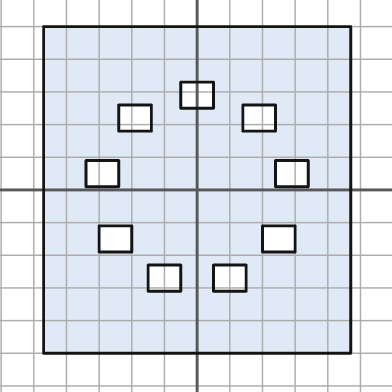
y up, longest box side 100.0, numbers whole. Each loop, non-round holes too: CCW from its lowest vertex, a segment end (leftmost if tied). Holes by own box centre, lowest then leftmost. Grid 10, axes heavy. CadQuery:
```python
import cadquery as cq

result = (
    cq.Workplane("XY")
    .moveTo(-47.0, -50.0)
    .lineTo(47.0, -50.0)
    .lineTo(47.0, 50.0)
    .lineTo(-47.0, 50.0)
    .close()
    .moveTo(-15.0, -31.0)
    .lineTo(-5.0, -31.0)
    .lineTo(-5.0, -23.0)
    .lineTo(-15.0, -23.0)
    .close()
    .moveTo(5.0, -31.0)
    .lineTo(15.0, -31.0)
    .lineTo(15.0, -23.0)
    .lineTo(5.0, -23.0)
    .close()
    .moveTo(-30.0, -19.0)
    .lineTo(-20.0, -19.0)
    .lineTo(-20.0, -11.0)
    .lineTo(-30.0, -11.0)
    .close()
    .moveTo(20.0, -19.0)
    .lineTo(30.0, -19.0)
    .lineTo(30.0, -11.0)
    .lineTo(20.0, -11.0)
    .close()
    .moveTo(-34.0, 1.0)
    .lineTo(-24.0, 1.0)
    .lineTo(-24.0, 9.0)
    .lineTo(-34.0, 9.0)
    .close()
    .moveTo(24.0, 1.0)
    .lineTo(34.0, 1.0)
    .lineTo(34.0, 9.0)
    .lineTo(24.0, 9.0)
    .close()
    .moveTo(-24.0, 18.0)
    .lineTo(-14.0, 18.0)
    .lineTo(-14.0, 26.0)
    .lineTo(-24.0, 26.0)
    .close()
    .moveTo(14.0, 18.0)
    .lineTo(24.0, 18.0)
    .lineTo(24.0, 26.0)
    .lineTo(14.0, 26.0)
    .close()
    .moveTo(-5.0, 25.0)
    .lineTo(5.0, 25.0)
    .lineTo(5.0, 33.0)
    .lineTo(-5.0, 33.0)
    .close()
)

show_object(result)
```